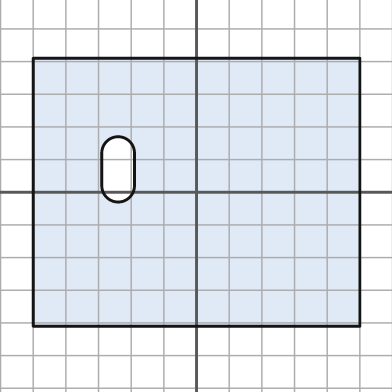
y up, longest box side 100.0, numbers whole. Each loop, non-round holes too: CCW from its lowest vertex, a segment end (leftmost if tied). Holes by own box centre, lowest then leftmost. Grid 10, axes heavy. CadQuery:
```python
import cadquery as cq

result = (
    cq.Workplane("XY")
    .moveTo(-50.0, -41.0)
    .lineTo(50.0, -41.0)
    .lineTo(50.0, 41.0)
    .lineTo(-50.0, 41.0)
    .close()
    .moveTo(-29.0, 2.0)
    .threePointArc((-24.0, -3.0), (-19.0, 2.0))
    .lineTo(-19.0, 12.0)
    .threePointArc((-24.0, 17.0), (-29.0, 12.0))
    .close()
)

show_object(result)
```